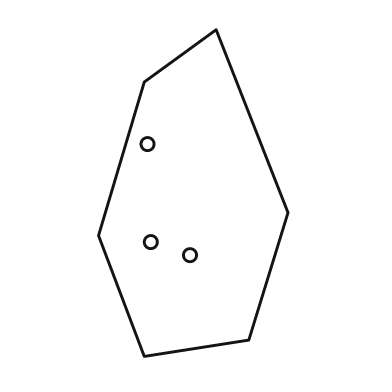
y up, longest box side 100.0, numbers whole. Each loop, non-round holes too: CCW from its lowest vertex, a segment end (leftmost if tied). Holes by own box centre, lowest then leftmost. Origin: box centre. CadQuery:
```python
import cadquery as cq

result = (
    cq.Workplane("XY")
    .moveTo(-15.0, -50.0)
    .lineTo(17.0, -45.0)
    .lineTo(29.0, -6.0)
    .lineTo(7.0, 50.0)
    .lineTo(-15.0, 34.0)
    .lineTo(-29.0, -13.0)
    .close()
    .moveTo(-1.0, -19.0)
    .circle(2.0)
    .moveTo(-13.0, -15.0)
    .circle(2.0)
    .moveTo(-14.0, 15.0)
    .circle(2.0)
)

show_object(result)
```